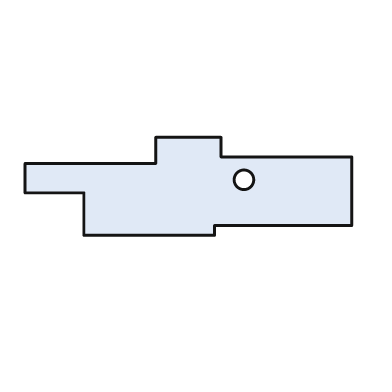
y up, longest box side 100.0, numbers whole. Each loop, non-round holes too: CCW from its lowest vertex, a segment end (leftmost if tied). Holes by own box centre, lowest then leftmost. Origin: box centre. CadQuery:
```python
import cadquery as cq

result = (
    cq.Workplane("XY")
    .moveTo(-32.0, -15.0)
    .lineTo(8.0, -15.0)
    .lineTo(8.0, -12.0)
    .lineTo(50.0, -12.0)
    .lineTo(50.0, 9.0)
    .lineTo(10.0, 9.0)
    .lineTo(10.0, 15.0)
    .lineTo(-10.0, 15.0)
    .lineTo(-10.0, 7.0)
    .lineTo(-50.0, 7.0)
    .lineTo(-50.0, -2.0)
    .lineTo(-32.0, -2.0)
    .close()
    .moveTo(17.0, 2.0)
    .circle(3.0)
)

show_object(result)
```